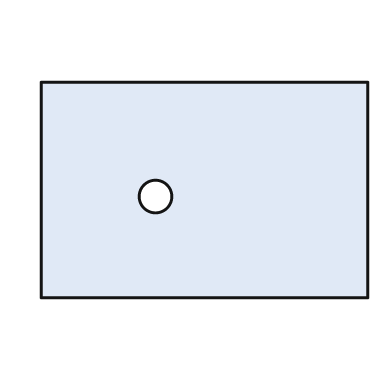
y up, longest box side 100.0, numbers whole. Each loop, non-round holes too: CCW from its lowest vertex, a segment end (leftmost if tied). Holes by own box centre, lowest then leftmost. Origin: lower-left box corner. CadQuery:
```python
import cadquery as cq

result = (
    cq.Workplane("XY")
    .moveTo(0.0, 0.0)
    .lineTo(100.0, 0.0)
    .lineTo(100.0, 66.0)
    .lineTo(0.0, 66.0)
    .close()
    .moveTo(35.0, 31.0)
    .circle(5.0)
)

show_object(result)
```